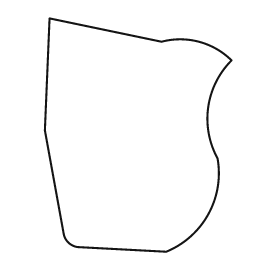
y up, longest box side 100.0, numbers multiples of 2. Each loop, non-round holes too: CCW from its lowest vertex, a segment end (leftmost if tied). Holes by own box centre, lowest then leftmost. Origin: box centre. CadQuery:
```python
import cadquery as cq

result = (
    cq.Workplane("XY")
    .moveTo(12.0, -50.0)
    .threePointArc((30.0, -34.0), (34.0, -10.0))
    .threePointArc((30.0, 12.0), (40.0, 32.0))
    .threePointArc((26.0, 40.0), (10.0, 40.0))
    .lineTo(-38.0, 50.0)
    .lineTo(-40.0, 2.0)
    .lineTo(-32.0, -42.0)
    .threePointArc((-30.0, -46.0), (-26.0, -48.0))
    .close()
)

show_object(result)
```